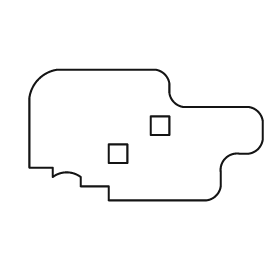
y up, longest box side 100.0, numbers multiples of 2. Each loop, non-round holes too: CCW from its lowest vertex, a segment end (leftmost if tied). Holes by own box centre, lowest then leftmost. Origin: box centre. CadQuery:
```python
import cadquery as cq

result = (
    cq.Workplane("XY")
    .moveTo(-16.0, -28.0)
    .lineTo(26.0, -28.0)
    .threePointArc((30.0, -26.0), (32.0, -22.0))
    .lineTo(32.0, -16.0)
    .threePointArc((34.0, -10.0), (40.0, -8.0))
    .lineTo(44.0, -8.0)
    .threePointArc((48.0, -6.0), (50.0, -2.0))
    .lineTo(50.0, 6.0)
    .threePointArc((48.0, 10.0), (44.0, 12.0))
    .lineTo(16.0, 12.0)
    .threePointArc((12.0, 14.0), (10.0, 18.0))
    .lineTo(10.0, 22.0)
    .threePointArc((8.0, 26.0), (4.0, 28.0))
    .lineTo(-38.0, 28.0)
    .threePointArc((-46.0, 24.0), (-50.0, 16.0))
    .lineTo(-50.0, -14.0)
    .lineTo(-40.0, -14.0)
    .lineTo(-40.0, -18.0)
    .threePointArc((-34.0, -16.0), (-28.0, -18.0))
    .lineTo(-28.0, -22.0)
    .lineTo(-16.0, -22.0)
    .close()
    .moveTo(-16.0, -12.0)
    .lineTo(-8.0, -12.0)
    .lineTo(-8.0, -4.0)
    .lineTo(-16.0, -4.0)
    .close()
    .moveTo(2.0, 0.0)
    .lineTo(10.0, 0.0)
    .lineTo(10.0, 8.0)
    .lineTo(2.0, 8.0)
    .close()
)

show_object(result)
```